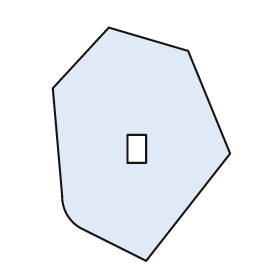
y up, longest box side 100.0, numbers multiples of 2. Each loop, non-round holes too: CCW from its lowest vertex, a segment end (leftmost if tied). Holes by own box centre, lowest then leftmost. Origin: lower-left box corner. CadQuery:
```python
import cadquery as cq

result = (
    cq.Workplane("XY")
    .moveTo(40.0, 0.0)
    .lineTo(76.0, 46.0)
    .lineTo(58.0, 90.0)
    .lineTo(24.0, 100.0)
    .lineTo(0.0, 74.0)
    .lineTo(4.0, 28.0)
    .threePointArc((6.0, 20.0), (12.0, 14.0))
    .close()
    .moveTo(32.0, 42.0)
    .lineTo(40.0, 42.0)
    .lineTo(40.0, 54.0)
    .lineTo(32.0, 54.0)
    .close()
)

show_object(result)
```